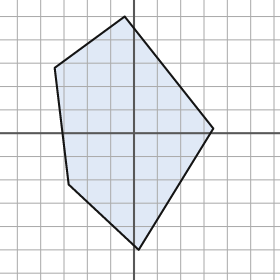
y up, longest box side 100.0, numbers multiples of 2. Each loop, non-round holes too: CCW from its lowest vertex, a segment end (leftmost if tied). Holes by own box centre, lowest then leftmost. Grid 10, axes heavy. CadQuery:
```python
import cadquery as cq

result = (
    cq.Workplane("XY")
    .moveTo(2.0, -50.0)
    .lineTo(34.0, 2.0)
    .lineTo(-4.0, 50.0)
    .lineTo(-34.0, 28.0)
    .lineTo(-28.0, -22.0)
    .close()
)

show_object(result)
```